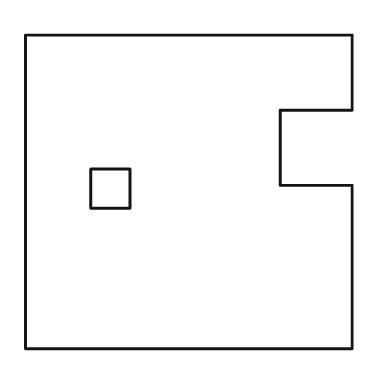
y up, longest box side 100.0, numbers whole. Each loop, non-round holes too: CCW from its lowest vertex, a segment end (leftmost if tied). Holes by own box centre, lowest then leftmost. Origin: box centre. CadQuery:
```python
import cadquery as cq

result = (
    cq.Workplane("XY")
    .moveTo(-50.0, -48.0)
    .lineTo(50.0, -48.0)
    .lineTo(50.0, 2.0)
    .lineTo(28.0, 2.0)
    .lineTo(28.0, 25.0)
    .lineTo(50.0, 25.0)
    .lineTo(50.0, 48.0)
    .lineTo(-50.0, 48.0)
    .close()
    .moveTo(-30.0, -5.0)
    .lineTo(-18.0, -5.0)
    .lineTo(-18.0, 7.0)
    .lineTo(-30.0, 7.0)
    .close()
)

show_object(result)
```